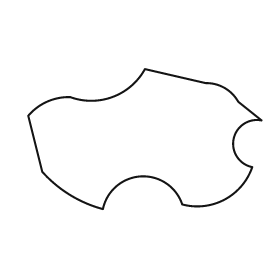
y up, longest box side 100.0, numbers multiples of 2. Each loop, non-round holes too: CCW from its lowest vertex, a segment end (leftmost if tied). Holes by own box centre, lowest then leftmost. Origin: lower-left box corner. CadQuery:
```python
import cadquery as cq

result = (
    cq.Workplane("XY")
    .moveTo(32.0, 0.0)
    .threePointArc((48.0, 14.0), (66.0, 2.0))
    .threePointArc((84.0, 4.0), (96.0, 18.0))
    .threePointArc((88.0, 30.0), (100.0, 38.0))
    .lineTo(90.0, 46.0)
    .threePointArc((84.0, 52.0), (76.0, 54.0))
    .lineTo(50.0, 60.0)
    .threePointArc((36.0, 48.0), (18.0, 48.0))
    .threePointArc((8.0, 46.0), (0.0, 40.0))
    .lineTo(6.0, 16.0)
    .threePointArc((18.0, 6.0), (32.0, 0.0))
    .close()
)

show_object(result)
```